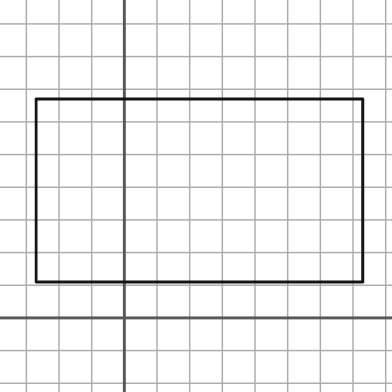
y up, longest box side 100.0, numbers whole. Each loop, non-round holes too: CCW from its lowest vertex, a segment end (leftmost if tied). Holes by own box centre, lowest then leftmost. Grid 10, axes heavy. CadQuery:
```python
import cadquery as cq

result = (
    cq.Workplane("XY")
    .moveTo(-27.0, 11.0)
    .lineTo(73.0, 11.0)
    .lineTo(73.0, 67.0)
    .lineTo(-27.0, 67.0)
    .close()
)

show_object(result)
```